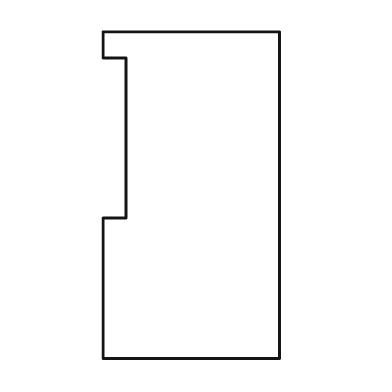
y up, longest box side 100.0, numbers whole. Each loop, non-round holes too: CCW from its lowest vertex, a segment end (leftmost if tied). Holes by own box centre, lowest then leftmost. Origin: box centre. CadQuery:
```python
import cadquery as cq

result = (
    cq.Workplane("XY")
    .moveTo(-27.0, -50.0)
    .lineTo(27.0, -50.0)
    .lineTo(27.0, 50.0)
    .lineTo(-27.0, 50.0)
    .lineTo(-27.0, 42.0)
    .lineTo(-20.0, 42.0)
    .lineTo(-20.0, -7.0)
    .lineTo(-27.0, -7.0)
    .close()
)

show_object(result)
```